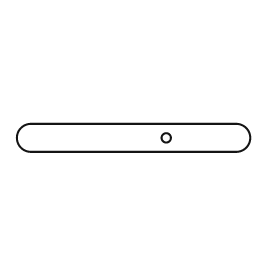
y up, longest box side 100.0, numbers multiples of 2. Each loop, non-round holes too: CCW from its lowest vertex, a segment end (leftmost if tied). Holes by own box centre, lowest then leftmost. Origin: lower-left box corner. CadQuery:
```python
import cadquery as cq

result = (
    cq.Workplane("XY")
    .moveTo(6.0, 0.0)
    .lineTo(94.0, 0.0)
    .threePointArc((100.0, 6.0), (94.0, 12.0))
    .lineTo(6.0, 12.0)
    .threePointArc((0.0, 6.0), (6.0, 0.0))
    .close()
    .moveTo(64.0, 6.0)
    .circle(2.0)
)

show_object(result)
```